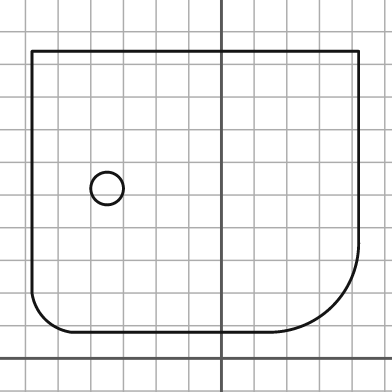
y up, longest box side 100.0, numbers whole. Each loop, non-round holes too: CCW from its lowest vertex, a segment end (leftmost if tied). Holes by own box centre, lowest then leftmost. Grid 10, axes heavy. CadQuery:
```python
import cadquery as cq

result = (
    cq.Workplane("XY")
    .moveTo(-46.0, 8.0)
    .lineTo(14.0, 8.0)
    .threePointArc((34.0, 16.0), (42.0, 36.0))
    .lineTo(42.0, 94.0)
    .lineTo(-58.0, 94.0)
    .lineTo(-58.0, 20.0)
    .threePointArc((-54.0, 12.0), (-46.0, 8.0))
    .close()
    .moveTo(-35.0, 52.0)
    .circle(5.0)
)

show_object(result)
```